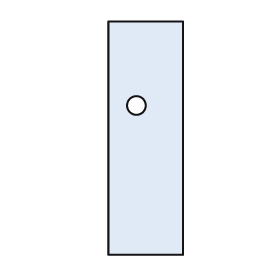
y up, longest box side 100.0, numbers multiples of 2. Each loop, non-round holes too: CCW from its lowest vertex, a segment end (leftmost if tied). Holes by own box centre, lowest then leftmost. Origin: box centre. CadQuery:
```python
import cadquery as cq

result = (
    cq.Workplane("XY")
    .moveTo(-16.0, -50.0)
    .lineTo(16.0, -50.0)
    .lineTo(16.0, 50.0)
    .lineTo(-16.0, 50.0)
    .close()
    .moveTo(-4.0, 14.0)
    .circle(4.0)
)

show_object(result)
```